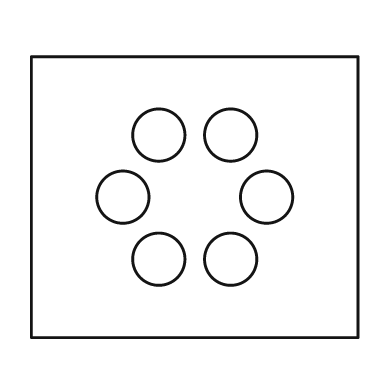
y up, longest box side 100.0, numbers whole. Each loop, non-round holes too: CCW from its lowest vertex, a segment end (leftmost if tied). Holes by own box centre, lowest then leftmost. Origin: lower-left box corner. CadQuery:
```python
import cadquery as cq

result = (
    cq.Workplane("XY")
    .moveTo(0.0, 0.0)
    .lineTo(100.0, 0.0)
    .lineTo(100.0, 86.0)
    .lineTo(0.0, 86.0)
    .close()
    .moveTo(39.0, 24.0)
    .circle(8.0)
    .moveTo(61.0, 24.0)
    .circle(8.0)
    .moveTo(28.0, 43.0)
    .circle(8.0)
    .moveTo(72.0, 43.0)
    .circle(8.0)
    .moveTo(39.0, 62.0)
    .circle(8.0)
    .moveTo(61.0, 62.0)
    .circle(8.0)
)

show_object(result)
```